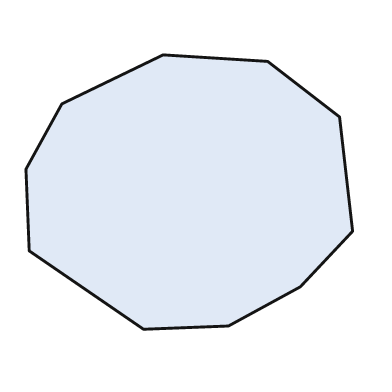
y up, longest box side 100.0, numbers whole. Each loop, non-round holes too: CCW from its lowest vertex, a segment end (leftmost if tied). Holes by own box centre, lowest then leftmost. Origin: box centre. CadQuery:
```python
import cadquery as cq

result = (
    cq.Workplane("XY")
    .moveTo(-14.0, -42.0)
    .lineTo(12.0, -41.0)
    .lineTo(34.0, -29.0)
    .lineTo(50.0, -12.0)
    .lineTo(46.0, 23.0)
    .lineTo(24.0, 40.0)
    .lineTo(-8.0, 42.0)
    .lineTo(-39.0, 27.0)
    .lineTo(-50.0, 7.0)
    .lineTo(-49.0, -18.0)
    .close()
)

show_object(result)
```